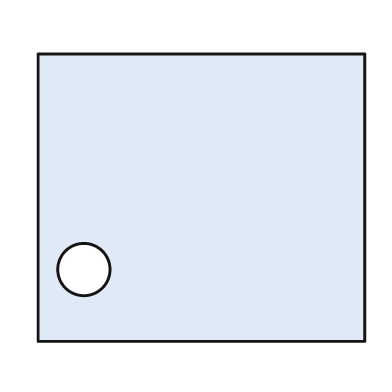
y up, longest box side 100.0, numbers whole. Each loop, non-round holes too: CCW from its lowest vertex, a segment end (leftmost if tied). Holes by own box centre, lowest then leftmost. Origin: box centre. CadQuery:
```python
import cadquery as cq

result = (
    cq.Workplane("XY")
    .moveTo(-50.0, -44.0)
    .lineTo(50.0, -44.0)
    .lineTo(50.0, 44.0)
    .lineTo(-50.0, 44.0)
    .close()
    .moveTo(-36.0, -22.0)
    .circle(8.0)
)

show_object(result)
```